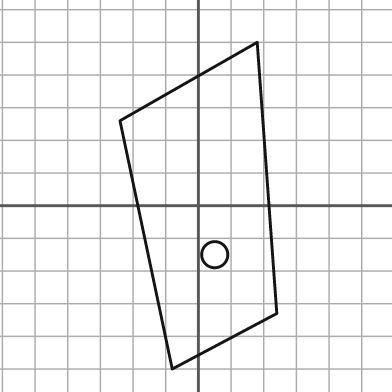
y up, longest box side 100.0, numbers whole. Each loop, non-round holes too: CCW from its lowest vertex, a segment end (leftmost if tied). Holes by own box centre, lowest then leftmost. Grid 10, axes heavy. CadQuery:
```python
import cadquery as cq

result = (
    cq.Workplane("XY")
    .moveTo(-8.0, -50.0)
    .lineTo(24.0, -33.0)
    .lineTo(18.0, 50.0)
    .lineTo(-24.0, 26.0)
    .close()
    .moveTo(5.0, -15.0)
    .circle(4.0)
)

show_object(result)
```